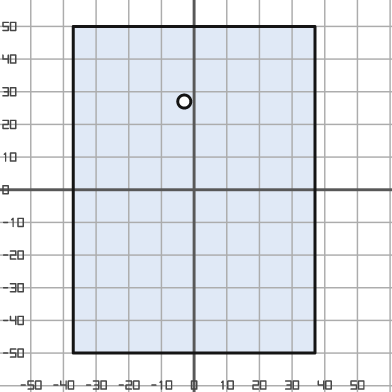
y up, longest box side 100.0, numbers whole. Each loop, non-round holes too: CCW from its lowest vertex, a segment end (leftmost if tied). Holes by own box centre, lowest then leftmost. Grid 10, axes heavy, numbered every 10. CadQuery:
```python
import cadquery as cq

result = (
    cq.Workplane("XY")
    .moveTo(-37.0, -50.0)
    .lineTo(37.0, -50.0)
    .lineTo(37.0, 50.0)
    .lineTo(-37.0, 50.0)
    .close()
    .moveTo(-3.0, 27.0)
    .circle(2.0)
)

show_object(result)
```